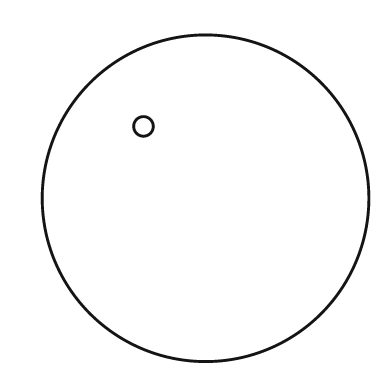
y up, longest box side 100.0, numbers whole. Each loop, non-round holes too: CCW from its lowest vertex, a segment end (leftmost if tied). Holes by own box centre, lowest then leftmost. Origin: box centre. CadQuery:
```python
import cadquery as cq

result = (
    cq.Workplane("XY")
    .moveTo(0.0, 0.0)
    .circle(50.0)
    .moveTo(-19.0, 22.0)
    .circle(3.0)
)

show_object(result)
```